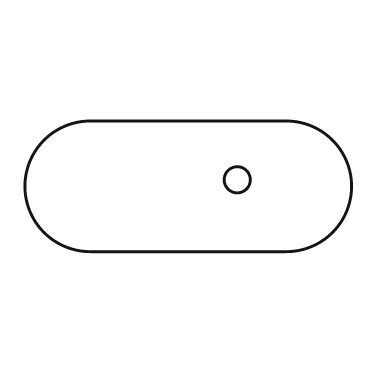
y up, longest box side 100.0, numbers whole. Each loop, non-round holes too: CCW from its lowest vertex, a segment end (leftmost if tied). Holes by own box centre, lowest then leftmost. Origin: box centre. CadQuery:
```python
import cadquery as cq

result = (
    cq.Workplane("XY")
    .moveTo(-30.0, -20.0)
    .lineTo(30.0, -20.0)
    .threePointArc((50.0, 0.0), (30.0, 20.0))
    .lineTo(-30.0, 20.0)
    .threePointArc((-50.0, 0.0), (-30.0, -20.0))
    .close()
    .moveTo(15.0, 2.0)
    .circle(4.0)
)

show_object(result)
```